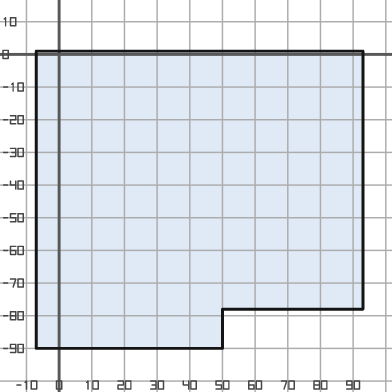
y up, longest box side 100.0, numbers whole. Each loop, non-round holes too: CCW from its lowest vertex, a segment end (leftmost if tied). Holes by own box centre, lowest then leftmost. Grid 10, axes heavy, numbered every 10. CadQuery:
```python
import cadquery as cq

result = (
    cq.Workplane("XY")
    .moveTo(-7.0, -90.0)
    .lineTo(50.0, -90.0)
    .lineTo(50.0, -78.0)
    .lineTo(93.0, -78.0)
    .lineTo(93.0, 1.0)
    .lineTo(-7.0, 1.0)
    .close()
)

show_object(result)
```